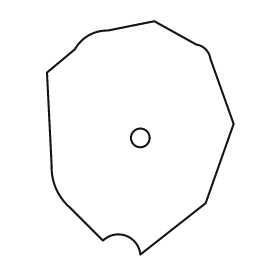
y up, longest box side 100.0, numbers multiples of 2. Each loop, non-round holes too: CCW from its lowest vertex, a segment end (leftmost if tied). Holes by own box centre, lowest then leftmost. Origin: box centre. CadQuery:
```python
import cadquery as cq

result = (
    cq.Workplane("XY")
    .moveTo(0.0, -50.0)
    .lineTo(28.0, -28.0)
    .lineTo(40.0, 6.0)
    .lineTo(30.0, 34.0)
    .threePointArc((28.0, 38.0), (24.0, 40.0))
    .lineTo(6.0, 50.0)
    .lineTo(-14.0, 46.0)
    .threePointArc((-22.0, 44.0), (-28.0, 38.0))
    .lineTo(-40.0, 28.0)
    .lineTo(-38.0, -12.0)
    .threePointArc((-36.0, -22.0), (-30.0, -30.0))
    .lineTo(-16.0, -44.0)
    .threePointArc((-6.0, -42.0), (0.0, -50.0))
    .close()
    .moveTo(0.0, 0.0)
    .circle(4.0)
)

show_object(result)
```